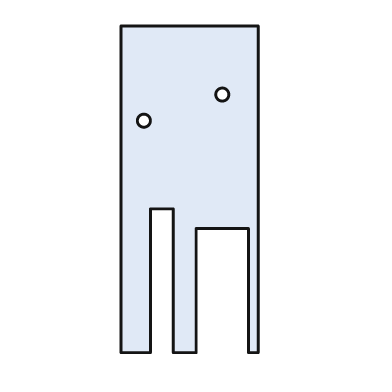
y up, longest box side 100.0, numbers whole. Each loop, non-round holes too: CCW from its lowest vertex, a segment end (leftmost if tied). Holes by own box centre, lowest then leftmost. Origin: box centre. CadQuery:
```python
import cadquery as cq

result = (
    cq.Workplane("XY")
    .moveTo(-21.0, -50.0)
    .lineTo(-12.0, -50.0)
    .lineTo(-12.0, -6.0)
    .lineTo(-5.0, -6.0)
    .lineTo(-5.0, -50.0)
    .lineTo(2.0, -50.0)
    .lineTo(2.0, -12.0)
    .lineTo(18.0, -12.0)
    .lineTo(18.0, -50.0)
    .lineTo(21.0, -50.0)
    .lineTo(21.0, 50.0)
    .lineTo(-21.0, 50.0)
    .close()
    .moveTo(-14.0, 21.0)
    .circle(2.0)
    .moveTo(10.0, 29.0)
    .circle(2.0)
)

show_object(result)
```